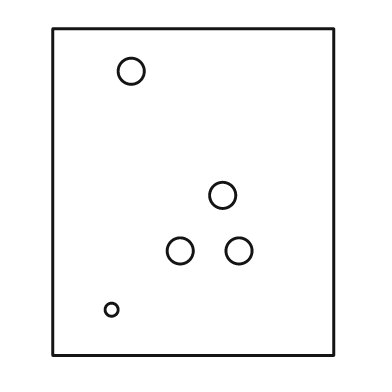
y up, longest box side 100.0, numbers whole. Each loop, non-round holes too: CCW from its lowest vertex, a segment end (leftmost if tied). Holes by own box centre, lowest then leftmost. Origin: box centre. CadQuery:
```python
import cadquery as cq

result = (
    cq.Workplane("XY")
    .moveTo(-43.0, -50.0)
    .lineTo(43.0, -50.0)
    .lineTo(43.0, 50.0)
    .lineTo(-43.0, 50.0)
    .close()
    .moveTo(-25.0, -36.0)
    .circle(2.0)
    .moveTo(-4.0, -18.0)
    .circle(4.0)
    .moveTo(14.0, -18.0)
    .circle(4.0)
    .moveTo(9.0, -1.0)
    .circle(4.0)
    .moveTo(-19.0, 37.0)
    .circle(4.0)
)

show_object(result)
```